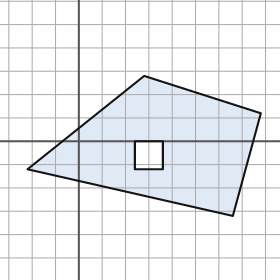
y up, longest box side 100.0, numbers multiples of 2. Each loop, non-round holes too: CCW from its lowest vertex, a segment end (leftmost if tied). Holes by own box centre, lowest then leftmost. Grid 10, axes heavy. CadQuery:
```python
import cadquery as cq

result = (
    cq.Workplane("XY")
    .moveTo(66.0, -32.0)
    .lineTo(78.0, 12.0)
    .lineTo(28.0, 28.0)
    .lineTo(-22.0, -12.0)
    .close()
    .moveTo(24.0, -12.0)
    .lineTo(36.0, -12.0)
    .lineTo(36.0, 0.0)
    .lineTo(24.0, 0.0)
    .close()
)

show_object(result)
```